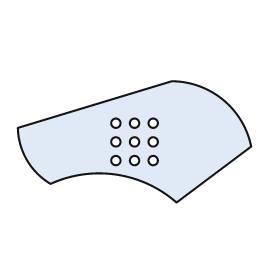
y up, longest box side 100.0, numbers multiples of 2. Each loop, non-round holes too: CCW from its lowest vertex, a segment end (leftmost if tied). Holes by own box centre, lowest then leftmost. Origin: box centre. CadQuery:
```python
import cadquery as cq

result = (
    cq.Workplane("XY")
    .moveTo(18.0, -26.0)
    .lineTo(50.0, -2.0)
    .threePointArc((38.0, 18.0), (16.0, 26.0))
    .lineTo(-50.0, 6.0)
    .threePointArc((-46.0, -8.0), (-36.0, -18.0))
    .threePointArc((-8.0, -14.0), (18.0, -26.0))
    .close()
    .moveTo(-8.0, -8.0)
    .circle(2.0)
    .moveTo(0.0, -8.0)
    .circle(2.0)
    .moveTo(8.0, -8.0)
    .circle(2.0)
    .moveTo(-8.0, 0.0)
    .circle(2.0)
    .moveTo(0.0, 0.0)
    .circle(2.0)
    .moveTo(8.0, 0.0)
    .circle(2.0)
    .moveTo(-8.0, 8.0)
    .circle(2.0)
    .moveTo(0.0, 8.0)
    .circle(2.0)
    .moveTo(8.0, 8.0)
    .circle(2.0)
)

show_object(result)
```